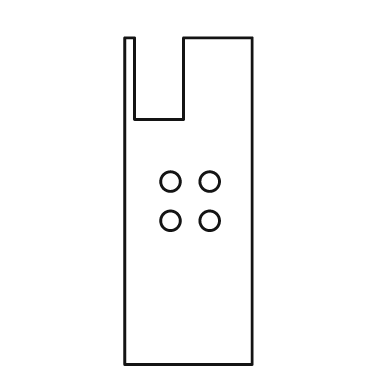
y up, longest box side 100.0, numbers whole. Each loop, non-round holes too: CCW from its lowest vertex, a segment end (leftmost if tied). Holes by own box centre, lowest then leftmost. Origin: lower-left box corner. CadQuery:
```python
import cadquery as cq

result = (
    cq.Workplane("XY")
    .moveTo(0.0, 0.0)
    .lineTo(39.0, 0.0)
    .lineTo(39.0, 100.0)
    .lineTo(18.0, 100.0)
    .lineTo(18.0, 75.0)
    .lineTo(3.0, 75.0)
    .lineTo(3.0, 100.0)
    .lineTo(0.0, 100.0)
    .close()
    .moveTo(14.0, 44.0)
    .circle(3.0)
    .moveTo(26.0, 44.0)
    .circle(3.0)
    .moveTo(14.0, 56.0)
    .circle(3.0)
    .moveTo(26.0, 56.0)
    .circle(3.0)
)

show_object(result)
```